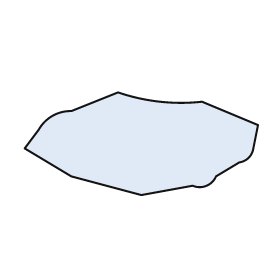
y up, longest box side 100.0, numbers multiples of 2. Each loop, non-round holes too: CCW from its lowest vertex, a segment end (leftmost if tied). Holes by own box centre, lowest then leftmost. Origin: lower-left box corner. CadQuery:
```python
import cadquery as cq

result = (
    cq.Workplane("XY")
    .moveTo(50.0, 0.0)
    .lineTo(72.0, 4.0)
    .threePointArc((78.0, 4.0), (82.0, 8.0))
    .lineTo(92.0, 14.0)
    .threePointArc((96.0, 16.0), (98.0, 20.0))
    .lineTo(100.0, 30.0)
    .lineTo(76.0, 40.0)
    .threePointArc((58.0, 40.0), (40.0, 44.0))
    .lineTo(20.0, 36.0)
    .threePointArc((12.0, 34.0), (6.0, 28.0))
    .lineTo(0.0, 20.0)
    .lineTo(20.0, 8.0)
    .close()
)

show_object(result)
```